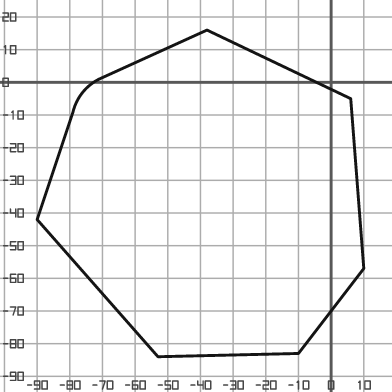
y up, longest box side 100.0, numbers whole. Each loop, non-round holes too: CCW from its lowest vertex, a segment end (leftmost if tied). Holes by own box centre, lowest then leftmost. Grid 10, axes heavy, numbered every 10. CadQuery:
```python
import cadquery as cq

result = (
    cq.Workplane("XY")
    .moveTo(-53.0, -84.0)
    .lineTo(-10.0, -83.0)
    .lineTo(10.0, -57.0)
    .lineTo(6.0, -5.0)
    .lineTo(-38.0, 16.0)
    .lineTo(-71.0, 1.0)
    .threePointArc((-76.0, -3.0), (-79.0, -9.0))
    .lineTo(-90.0, -42.0)
    .close()
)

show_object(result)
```